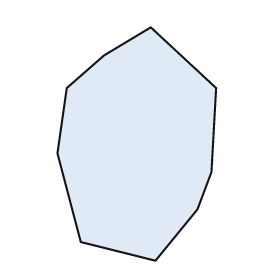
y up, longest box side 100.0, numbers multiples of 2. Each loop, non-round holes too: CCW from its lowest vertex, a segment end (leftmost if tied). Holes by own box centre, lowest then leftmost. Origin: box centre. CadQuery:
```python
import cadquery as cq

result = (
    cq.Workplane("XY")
    .moveTo(8.0, -50.0)
    .lineTo(26.0, -28.0)
    .lineTo(32.0, -12.0)
    .lineTo(34.0, 24.0)
    .lineTo(6.0, 50.0)
    .lineTo(-14.0, 38.0)
    .lineTo(-30.0, 24.0)
    .lineTo(-34.0, -4.0)
    .lineTo(-24.0, -42.0)
    .close()
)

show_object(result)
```